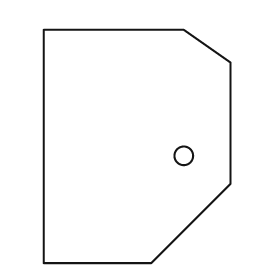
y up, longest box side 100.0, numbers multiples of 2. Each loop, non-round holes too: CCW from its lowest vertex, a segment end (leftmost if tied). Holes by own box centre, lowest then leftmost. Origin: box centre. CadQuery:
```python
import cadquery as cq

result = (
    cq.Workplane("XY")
    .moveTo(-40.0, -50.0)
    .lineTo(6.0, -50.0)
    .lineTo(40.0, -16.0)
    .lineTo(40.0, 36.0)
    .lineTo(20.0, 50.0)
    .lineTo(-40.0, 50.0)
    .close()
    .moveTo(20.0, -4.0)
    .circle(4.0)
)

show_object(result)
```